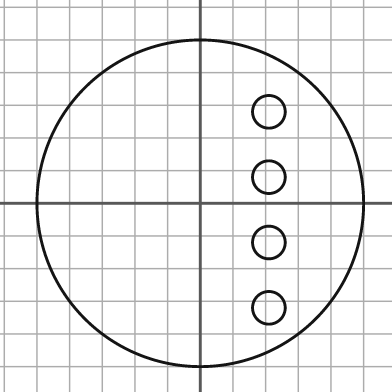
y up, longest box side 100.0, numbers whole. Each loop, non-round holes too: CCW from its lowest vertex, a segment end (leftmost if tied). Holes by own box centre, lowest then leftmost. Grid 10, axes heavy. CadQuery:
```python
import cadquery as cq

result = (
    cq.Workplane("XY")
    .moveTo(0.0, 0.0)
    .circle(50.0)
    .moveTo(21.0, -32.0)
    .circle(5.0)
    .moveTo(21.0, -12.0)
    .circle(5.0)
    .moveTo(21.0, 8.0)
    .circle(5.0)
    .moveTo(21.0, 28.0)
    .circle(5.0)
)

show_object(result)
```